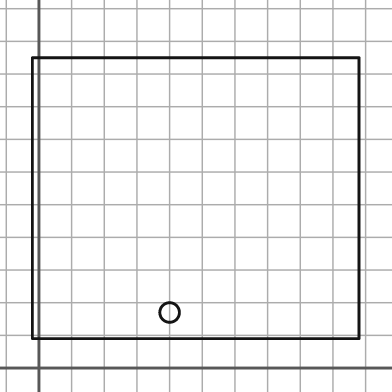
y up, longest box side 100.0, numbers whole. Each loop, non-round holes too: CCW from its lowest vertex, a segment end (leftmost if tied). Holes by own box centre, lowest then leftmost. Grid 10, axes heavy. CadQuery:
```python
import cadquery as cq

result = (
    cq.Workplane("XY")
    .moveTo(-2.0, 9.0)
    .lineTo(98.0, 9.0)
    .lineTo(98.0, 95.0)
    .lineTo(-2.0, 95.0)
    .close()
    .moveTo(40.0, 17.0)
    .circle(3.0)
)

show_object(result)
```